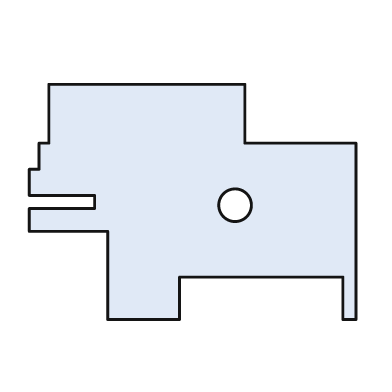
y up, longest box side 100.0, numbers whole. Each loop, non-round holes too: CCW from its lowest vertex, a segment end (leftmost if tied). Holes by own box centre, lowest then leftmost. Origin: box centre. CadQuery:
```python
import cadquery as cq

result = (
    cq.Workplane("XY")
    .moveTo(-26.0, -36.0)
    .lineTo(-4.0, -36.0)
    .lineTo(-4.0, -23.0)
    .lineTo(46.0, -23.0)
    .lineTo(46.0, -36.0)
    .lineTo(50.0, -36.0)
    .lineTo(50.0, 18.0)
    .lineTo(16.0, 18.0)
    .lineTo(16.0, 36.0)
    .lineTo(-44.0, 36.0)
    .lineTo(-44.0, 18.0)
    .lineTo(-47.0, 18.0)
    .lineTo(-47.0, 10.0)
    .lineTo(-50.0, 10.0)
    .lineTo(-50.0, 2.0)
    .lineTo(-30.0, 2.0)
    .lineTo(-30.0, -2.0)
    .lineTo(-50.0, -2.0)
    .lineTo(-50.0, -9.0)
    .lineTo(-26.0, -9.0)
    .close()
    .moveTo(13.0, -1.0)
    .circle(5.0)
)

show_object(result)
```